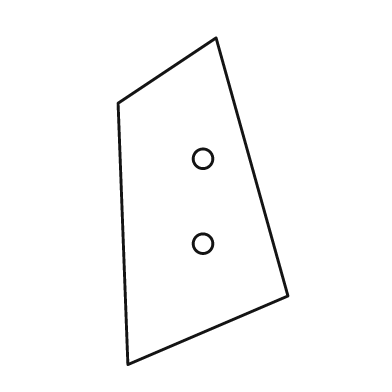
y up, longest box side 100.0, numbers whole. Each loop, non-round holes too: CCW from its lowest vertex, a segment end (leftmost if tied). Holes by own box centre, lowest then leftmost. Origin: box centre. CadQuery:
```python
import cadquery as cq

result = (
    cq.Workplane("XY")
    .moveTo(-23.0, -50.0)
    .lineTo(26.0, -29.0)
    .lineTo(4.0, 50.0)
    .lineTo(-26.0, 30.0)
    .close()
    .moveTo(0.0, -13.0)
    .circle(3.0)
    .moveTo(0.0, 13.0)
    .circle(3.0)
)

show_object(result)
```